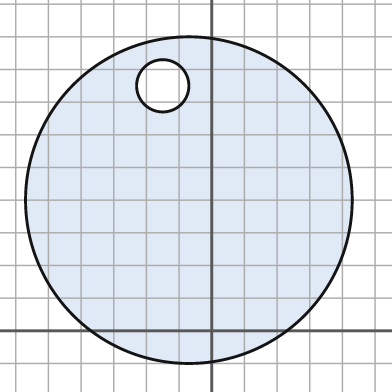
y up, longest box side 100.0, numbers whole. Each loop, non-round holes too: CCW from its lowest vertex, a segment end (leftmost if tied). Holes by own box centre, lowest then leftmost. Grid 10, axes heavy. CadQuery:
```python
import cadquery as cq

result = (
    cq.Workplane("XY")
    .moveTo(-7.0, 40.0)
    .circle(50.0)
    .moveTo(-15.0, 75.0)
    .circle(8.0)
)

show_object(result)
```